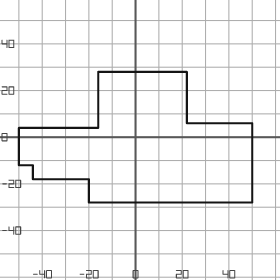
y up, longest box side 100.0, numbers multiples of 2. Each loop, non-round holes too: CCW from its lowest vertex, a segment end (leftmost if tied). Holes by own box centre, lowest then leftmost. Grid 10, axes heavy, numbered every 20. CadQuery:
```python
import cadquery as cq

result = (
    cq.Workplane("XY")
    .moveTo(-20.0, -28.0)
    .lineTo(50.0, -28.0)
    .lineTo(50.0, 6.0)
    .lineTo(22.0, 6.0)
    .lineTo(22.0, 28.0)
    .lineTo(-16.0, 28.0)
    .lineTo(-16.0, 4.0)
    .lineTo(-50.0, 4.0)
    .lineTo(-50.0, -12.0)
    .lineTo(-44.0, -12.0)
    .lineTo(-44.0, -18.0)
    .lineTo(-20.0, -18.0)
    .close()
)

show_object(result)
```